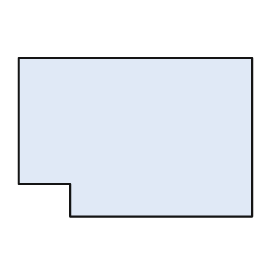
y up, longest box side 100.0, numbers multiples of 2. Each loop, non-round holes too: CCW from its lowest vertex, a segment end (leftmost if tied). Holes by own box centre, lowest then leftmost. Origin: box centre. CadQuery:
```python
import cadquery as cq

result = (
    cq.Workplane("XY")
    .moveTo(-28.0, -34.0)
    .lineTo(50.0, -34.0)
    .lineTo(50.0, 34.0)
    .lineTo(-50.0, 34.0)
    .lineTo(-50.0, -20.0)
    .lineTo(-28.0, -20.0)
    .close()
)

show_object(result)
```